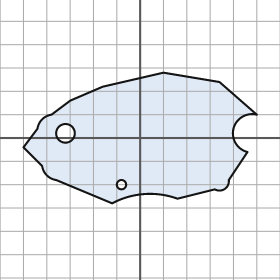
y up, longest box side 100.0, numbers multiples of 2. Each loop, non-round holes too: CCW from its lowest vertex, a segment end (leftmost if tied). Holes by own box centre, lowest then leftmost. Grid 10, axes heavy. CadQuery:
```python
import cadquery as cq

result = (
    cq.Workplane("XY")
    .moveTo(-12.0, -28.0)
    .threePointArc((2.0, -24.0), (16.0, -26.0))
    .lineTo(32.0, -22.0)
    .threePointArc((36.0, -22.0), (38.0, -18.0))
    .lineTo(46.0, -6.0)
    .threePointArc((40.0, 4.0), (50.0, 10.0))
    .lineTo(34.0, 24.0)
    .lineTo(10.0, 28.0)
    .lineTo(-16.0, 22.0)
    .lineTo(-30.0, 16.0)
    .lineTo(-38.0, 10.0)
    .threePointArc((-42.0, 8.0), (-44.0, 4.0))
    .lineTo(-50.0, -4.0)
    .lineTo(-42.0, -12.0)
    .threePointArc((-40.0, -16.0), (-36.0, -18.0))
    .close()
    .moveTo(-8.0, -20.0)
    .circle(2.0)
    .moveTo(-32.0, 2.0)
    .circle(4.0)
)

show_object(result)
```